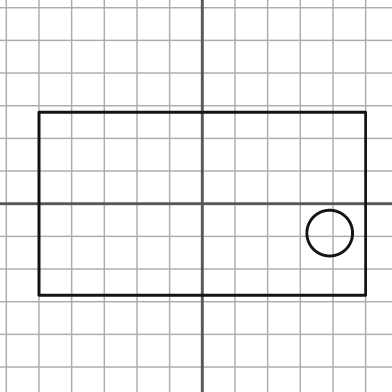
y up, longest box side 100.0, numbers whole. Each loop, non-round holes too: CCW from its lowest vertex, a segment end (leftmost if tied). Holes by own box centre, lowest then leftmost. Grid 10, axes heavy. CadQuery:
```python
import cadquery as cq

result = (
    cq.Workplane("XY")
    .moveTo(-50.0, -28.0)
    .lineTo(50.0, -28.0)
    .lineTo(50.0, 28.0)
    .lineTo(-50.0, 28.0)
    .close()
    .moveTo(39.0, -9.0)
    .circle(7.0)
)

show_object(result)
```